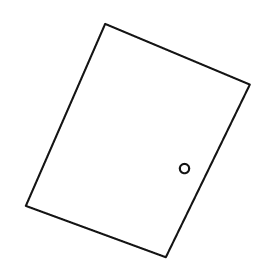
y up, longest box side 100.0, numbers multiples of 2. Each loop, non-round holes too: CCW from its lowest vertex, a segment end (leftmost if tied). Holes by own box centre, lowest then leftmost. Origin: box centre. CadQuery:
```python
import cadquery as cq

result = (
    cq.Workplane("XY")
    .moveTo(12.0, -50.0)
    .lineTo(48.0, 24.0)
    .lineTo(-14.0, 50.0)
    .lineTo(-48.0, -28.0)
    .close()
    .moveTo(20.0, -12.0)
    .circle(2.0)
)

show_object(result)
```